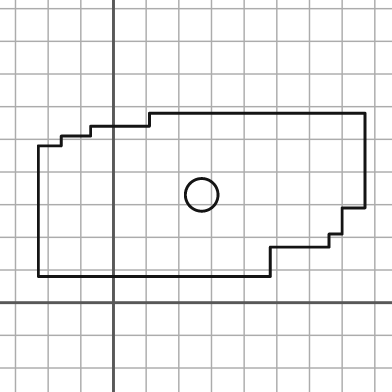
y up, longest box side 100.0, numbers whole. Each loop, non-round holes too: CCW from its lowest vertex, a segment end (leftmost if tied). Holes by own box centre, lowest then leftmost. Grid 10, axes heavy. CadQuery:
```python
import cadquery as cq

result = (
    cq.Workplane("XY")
    .moveTo(-23.0, 8.0)
    .lineTo(48.0, 8.0)
    .lineTo(48.0, 17.0)
    .lineTo(66.0, 17.0)
    .lineTo(66.0, 21.0)
    .lineTo(70.0, 21.0)
    .lineTo(70.0, 29.0)
    .lineTo(77.0, 29.0)
    .lineTo(77.0, 58.0)
    .lineTo(11.0, 58.0)
    .lineTo(11.0, 54.0)
    .lineTo(-7.0, 54.0)
    .lineTo(-7.0, 51.0)
    .lineTo(-16.0, 51.0)
    .lineTo(-16.0, 48.0)
    .lineTo(-23.0, 48.0)
    .close()
    .moveTo(27.0, 33.0)
    .circle(5.0)
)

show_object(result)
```